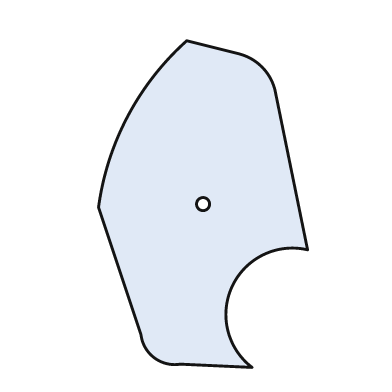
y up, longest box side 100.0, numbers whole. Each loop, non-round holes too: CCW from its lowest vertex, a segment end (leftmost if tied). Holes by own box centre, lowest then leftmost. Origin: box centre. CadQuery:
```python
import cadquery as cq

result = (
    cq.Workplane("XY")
    .moveTo(15.0, -50.0)
    .threePointArc((9.0, -25.0), (32.0, -14.0))
    .lineTo(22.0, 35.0)
    .threePointArc((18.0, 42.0), (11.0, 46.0))
    .lineTo(-5.0, 50.0)
    .threePointArc((-23.0, 27.0), (-32.0, -1.0))
    .lineTo(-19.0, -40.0)
    .threePointArc((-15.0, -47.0), (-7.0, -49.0))
    .close()
    .moveTo(0.0, 0.0)
    .circle(2.0)
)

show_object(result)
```